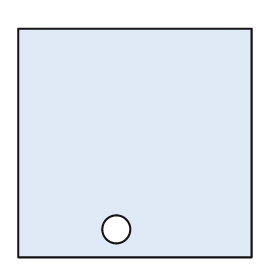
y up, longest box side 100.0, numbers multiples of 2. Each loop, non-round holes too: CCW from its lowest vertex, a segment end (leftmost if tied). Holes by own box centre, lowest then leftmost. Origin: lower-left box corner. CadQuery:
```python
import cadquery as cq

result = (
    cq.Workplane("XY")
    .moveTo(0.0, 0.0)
    .lineTo(100.0, 0.0)
    .lineTo(100.0, 98.0)
    .lineTo(0.0, 98.0)
    .close()
    .moveTo(42.0, 12.0)
    .circle(6.0)
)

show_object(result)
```